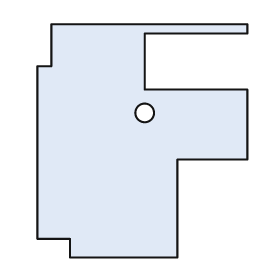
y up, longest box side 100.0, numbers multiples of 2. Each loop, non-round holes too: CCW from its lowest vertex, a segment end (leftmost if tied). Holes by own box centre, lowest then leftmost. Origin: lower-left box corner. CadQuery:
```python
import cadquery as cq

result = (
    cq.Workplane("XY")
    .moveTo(14.0, 0.0)
    .lineTo(60.0, 0.0)
    .lineTo(60.0, 42.0)
    .lineTo(90.0, 42.0)
    .lineTo(90.0, 72.0)
    .lineTo(46.0, 72.0)
    .lineTo(46.0, 96.0)
    .lineTo(90.0, 96.0)
    .lineTo(90.0, 100.0)
    .lineTo(6.0, 100.0)
    .lineTo(6.0, 82.0)
    .lineTo(0.0, 82.0)
    .lineTo(0.0, 8.0)
    .lineTo(14.0, 8.0)
    .close()
    .moveTo(46.0, 62.0)
    .circle(4.0)
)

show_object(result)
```